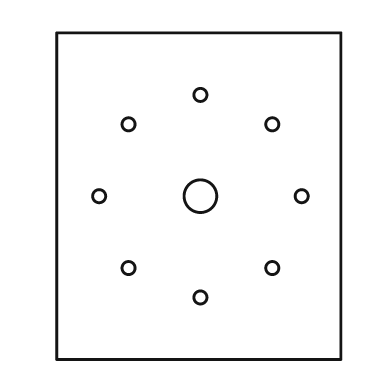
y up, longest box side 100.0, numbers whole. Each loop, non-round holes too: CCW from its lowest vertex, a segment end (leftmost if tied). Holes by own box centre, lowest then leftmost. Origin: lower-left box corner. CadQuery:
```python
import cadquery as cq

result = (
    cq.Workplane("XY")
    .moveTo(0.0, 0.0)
    .lineTo(87.0, 0.0)
    .lineTo(87.0, 100.0)
    .lineTo(0.0, 100.0)
    .close()
    .moveTo(44.0, 19.0)
    .circle(2.0)
    .moveTo(22.0, 28.0)
    .circle(2.0)
    .moveTo(66.0, 28.0)
    .circle(2.0)
    .moveTo(13.0, 50.0)
    .circle(2.0)
    .moveTo(44.0, 50.0)
    .circle(5.0)
    .moveTo(75.0, 50.0)
    .circle(2.0)
    .moveTo(22.0, 72.0)
    .circle(2.0)
    .moveTo(66.0, 72.0)
    .circle(2.0)
    .moveTo(44.0, 81.0)
    .circle(2.0)
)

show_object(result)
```